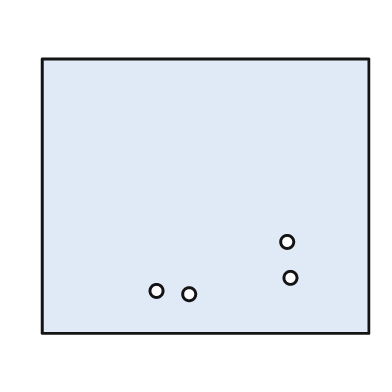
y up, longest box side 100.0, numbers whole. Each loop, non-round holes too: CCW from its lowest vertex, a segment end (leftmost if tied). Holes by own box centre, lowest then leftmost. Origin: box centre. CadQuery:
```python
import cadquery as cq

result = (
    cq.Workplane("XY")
    .moveTo(-50.0, -42.0)
    .lineTo(50.0, -42.0)
    .lineTo(50.0, 42.0)
    .lineTo(-50.0, 42.0)
    .close()
    .moveTo(-5.0, -30.0)
    .circle(2.0)
    .moveTo(-15.0, -29.0)
    .circle(2.0)
    .moveTo(26.0, -25.0)
    .circle(2.0)
    .moveTo(25.0, -14.0)
    .circle(2.0)
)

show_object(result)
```